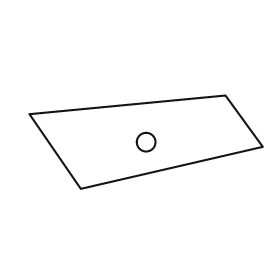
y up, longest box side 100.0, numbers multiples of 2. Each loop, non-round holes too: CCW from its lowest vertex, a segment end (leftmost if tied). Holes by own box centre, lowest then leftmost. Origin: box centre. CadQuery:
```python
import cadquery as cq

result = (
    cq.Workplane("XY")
    .moveTo(-28.0, -20.0)
    .lineTo(50.0, -2.0)
    .lineTo(34.0, 20.0)
    .lineTo(-50.0, 12.0)
    .close()
    .moveTo(0.0, 0.0)
    .circle(4.0)
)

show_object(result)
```